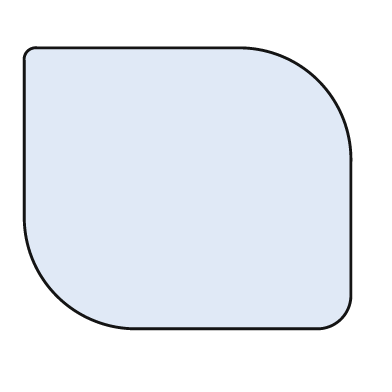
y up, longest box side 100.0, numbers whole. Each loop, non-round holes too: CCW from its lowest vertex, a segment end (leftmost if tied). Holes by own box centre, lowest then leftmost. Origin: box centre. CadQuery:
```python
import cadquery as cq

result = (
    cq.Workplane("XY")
    .moveTo(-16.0, -43.0)
    .lineTo(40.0, -43.0)
    .threePointArc((47.0, -40.0), (50.0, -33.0))
    .lineTo(50.0, 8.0)
    .threePointArc((40.0, 33.0), (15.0, 43.0))
    .lineTo(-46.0, 43.0)
    .threePointArc((-49.0, 42.0), (-50.0, 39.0))
    .lineTo(-50.0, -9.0)
    .threePointArc((-40.0, -33.0), (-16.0, -43.0))
    .close()
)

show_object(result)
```